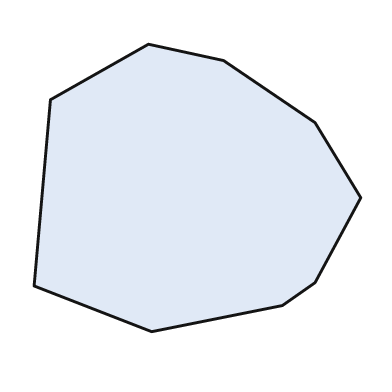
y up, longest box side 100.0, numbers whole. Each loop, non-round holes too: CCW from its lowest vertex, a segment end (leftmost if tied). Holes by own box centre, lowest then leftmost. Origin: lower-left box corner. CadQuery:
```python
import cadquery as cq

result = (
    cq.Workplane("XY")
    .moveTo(36.0, 0.0)
    .lineTo(76.0, 8.0)
    .lineTo(86.0, 15.0)
    .lineTo(100.0, 41.0)
    .lineTo(86.0, 64.0)
    .lineTo(58.0, 83.0)
    .lineTo(35.0, 88.0)
    .lineTo(5.0, 71.0)
    .lineTo(0.0, 14.0)
    .close()
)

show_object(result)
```